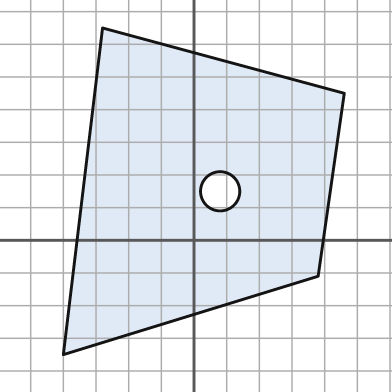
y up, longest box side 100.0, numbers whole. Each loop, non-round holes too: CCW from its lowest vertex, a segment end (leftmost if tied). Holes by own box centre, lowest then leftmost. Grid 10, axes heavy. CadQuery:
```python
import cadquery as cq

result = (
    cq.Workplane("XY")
    .moveTo(-40.0, -35.0)
    .lineTo(38.0, -11.0)
    .lineTo(46.0, 45.0)
    .lineTo(-28.0, 65.0)
    .close()
    .moveTo(8.0, 15.0)
    .circle(6.0)
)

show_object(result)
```